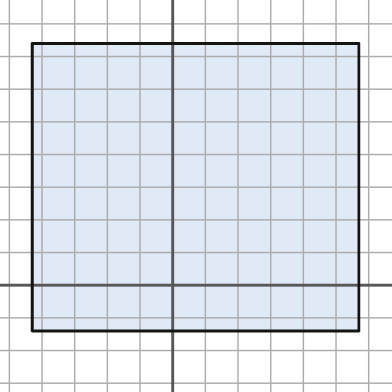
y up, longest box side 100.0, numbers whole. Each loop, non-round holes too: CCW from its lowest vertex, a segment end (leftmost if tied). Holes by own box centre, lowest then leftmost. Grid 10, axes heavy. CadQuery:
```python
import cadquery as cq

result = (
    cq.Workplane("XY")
    .moveTo(-43.0, -14.0)
    .lineTo(57.0, -14.0)
    .lineTo(57.0, 74.0)
    .lineTo(-43.0, 74.0)
    .close()
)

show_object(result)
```